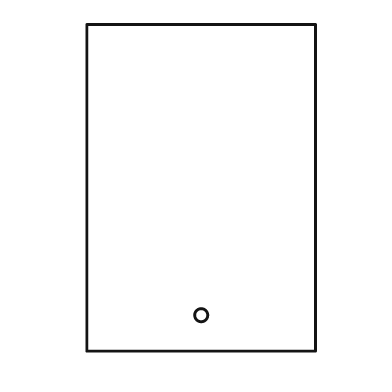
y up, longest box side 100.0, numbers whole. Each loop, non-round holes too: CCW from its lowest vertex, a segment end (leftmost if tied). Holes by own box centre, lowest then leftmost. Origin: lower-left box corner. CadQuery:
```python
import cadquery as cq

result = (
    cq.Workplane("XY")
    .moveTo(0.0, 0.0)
    .lineTo(70.0, 0.0)
    .lineTo(70.0, 100.0)
    .lineTo(0.0, 100.0)
    .close()
    .moveTo(35.0, 11.0)
    .circle(2.0)
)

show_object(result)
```